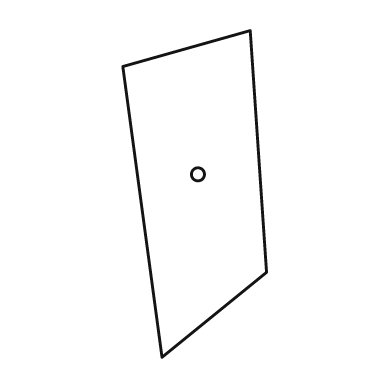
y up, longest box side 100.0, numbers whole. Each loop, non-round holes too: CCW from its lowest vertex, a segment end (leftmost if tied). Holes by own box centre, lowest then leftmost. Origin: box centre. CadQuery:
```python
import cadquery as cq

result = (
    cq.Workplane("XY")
    .moveTo(-10.0, -50.0)
    .lineTo(22.0, -24.0)
    .lineTo(17.0, 50.0)
    .lineTo(-22.0, 39.0)
    .close()
    .moveTo(1.0, 6.0)
    .circle(2.0)
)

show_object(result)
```